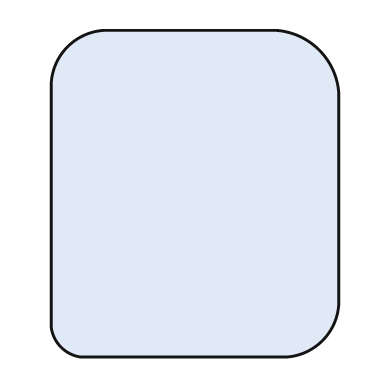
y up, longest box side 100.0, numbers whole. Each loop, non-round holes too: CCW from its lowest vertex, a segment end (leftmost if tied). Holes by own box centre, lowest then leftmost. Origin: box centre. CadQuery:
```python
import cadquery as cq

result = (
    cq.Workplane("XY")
    .moveTo(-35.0, -50.0)
    .lineTo(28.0, -50.0)
    .threePointArc((39.0, -45.0), (44.0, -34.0))
    .lineTo(44.0, 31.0)
    .threePointArc((38.0, 44.0), (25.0, 50.0))
    .lineTo(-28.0, 50.0)
    .threePointArc((-39.0, 45.0), (-44.0, 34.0))
    .lineTo(-44.0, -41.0)
    .threePointArc((-41.0, -47.0), (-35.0, -50.0))
    .close()
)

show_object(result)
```